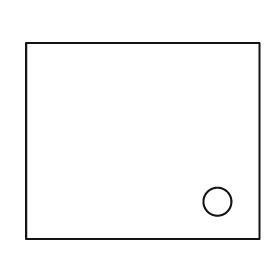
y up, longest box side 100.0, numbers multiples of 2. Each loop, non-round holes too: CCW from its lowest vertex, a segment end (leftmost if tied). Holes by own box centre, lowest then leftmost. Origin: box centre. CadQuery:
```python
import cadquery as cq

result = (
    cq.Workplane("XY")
    .moveTo(-50.0, -42.0)
    .lineTo(50.0, -42.0)
    .lineTo(50.0, 42.0)
    .lineTo(-50.0, 42.0)
    .close()
    .moveTo(32.0, -26.0)
    .circle(6.0)
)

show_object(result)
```